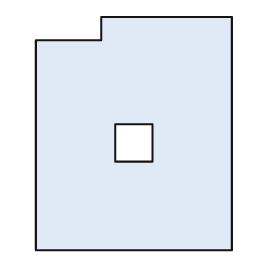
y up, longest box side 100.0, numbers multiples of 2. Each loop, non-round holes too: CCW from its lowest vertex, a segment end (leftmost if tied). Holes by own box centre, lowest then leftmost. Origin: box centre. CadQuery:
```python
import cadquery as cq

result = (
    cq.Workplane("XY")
    .moveTo(-42.0, -50.0)
    .lineTo(42.0, -50.0)
    .lineTo(42.0, 50.0)
    .lineTo(-14.0, 50.0)
    .lineTo(-14.0, 40.0)
    .lineTo(-42.0, 40.0)
    .close()
    .moveTo(-8.0, -12.0)
    .lineTo(8.0, -12.0)
    .lineTo(8.0, 4.0)
    .lineTo(-8.0, 4.0)
    .close()
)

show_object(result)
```